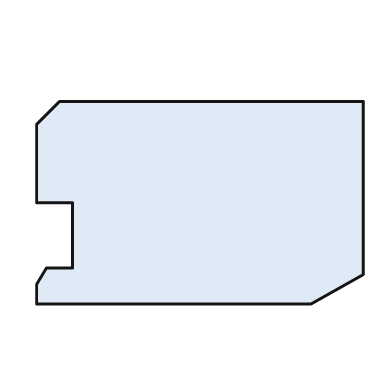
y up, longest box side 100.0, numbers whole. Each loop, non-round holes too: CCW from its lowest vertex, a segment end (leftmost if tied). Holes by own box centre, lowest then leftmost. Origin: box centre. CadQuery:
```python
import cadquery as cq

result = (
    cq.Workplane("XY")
    .moveTo(-50.0, -31.0)
    .lineTo(34.0, -31.0)
    .lineTo(50.0, -22.0)
    .lineTo(50.0, 31.0)
    .lineTo(-43.0, 31.0)
    .lineTo(-50.0, 24.0)
    .lineTo(-50.0, 0.0)
    .lineTo(-39.0, 0.0)
    .lineTo(-39.0, -20.0)
    .lineTo(-47.0, -20.0)
    .lineTo(-50.0, -25.0)
    .close()
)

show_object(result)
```